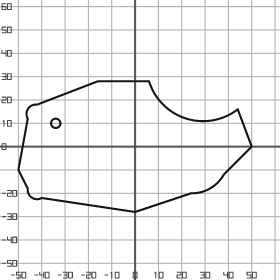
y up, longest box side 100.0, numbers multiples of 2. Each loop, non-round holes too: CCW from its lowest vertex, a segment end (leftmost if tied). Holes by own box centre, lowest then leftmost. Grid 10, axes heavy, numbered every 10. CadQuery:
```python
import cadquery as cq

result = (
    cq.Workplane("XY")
    .moveTo(0.0, -28.0)
    .lineTo(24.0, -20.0)
    .threePointArc((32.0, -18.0), (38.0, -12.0))
    .lineTo(50.0, 0.0)
    .lineTo(44.0, 16.0)
    .threePointArc((22.0, 12.0), (6.0, 28.0))
    .lineTo(-16.0, 28.0)
    .lineTo(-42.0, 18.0)
    .threePointArc((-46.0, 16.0), (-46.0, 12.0))
    .lineTo(-50.0, -10.0)
    .lineTo(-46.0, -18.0)
    .threePointArc((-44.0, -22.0), (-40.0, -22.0))
    .close()
    .moveTo(-34.0, 10.0)
    .circle(2.0)
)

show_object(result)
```